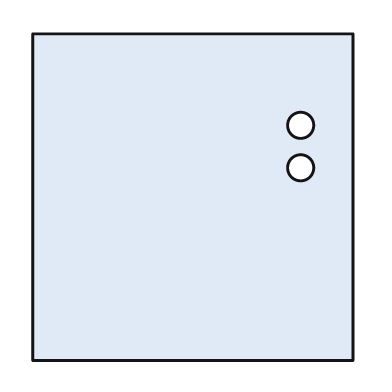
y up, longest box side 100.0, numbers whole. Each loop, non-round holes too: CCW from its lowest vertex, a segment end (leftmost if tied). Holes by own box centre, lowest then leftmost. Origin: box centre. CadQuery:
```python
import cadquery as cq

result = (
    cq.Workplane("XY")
    .moveTo(-49.0, -50.0)
    .lineTo(49.0, -50.0)
    .lineTo(49.0, 50.0)
    .lineTo(-49.0, 50.0)
    .close()
    .moveTo(33.0, 9.0)
    .circle(4.0)
    .moveTo(33.0, 22.0)
    .circle(4.0)
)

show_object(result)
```